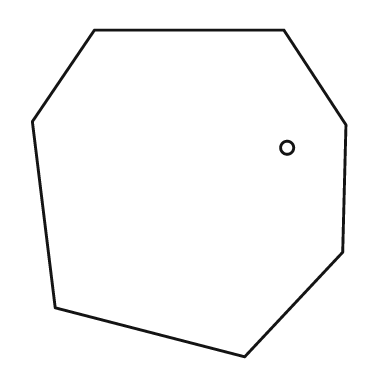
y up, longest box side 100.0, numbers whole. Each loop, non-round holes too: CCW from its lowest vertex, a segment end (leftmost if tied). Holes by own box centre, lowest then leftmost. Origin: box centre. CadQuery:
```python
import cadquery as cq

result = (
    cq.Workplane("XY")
    .moveTo(17.0, -50.0)
    .lineTo(47.0, -18.0)
    .lineTo(48.0, 21.0)
    .lineTo(29.0, 50.0)
    .lineTo(-29.0, 50.0)
    .lineTo(-48.0, 22.0)
    .lineTo(-41.0, -35.0)
    .close()
    .moveTo(30.0, 14.0)
    .circle(2.0)
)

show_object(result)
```